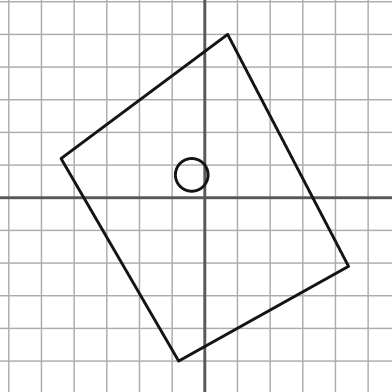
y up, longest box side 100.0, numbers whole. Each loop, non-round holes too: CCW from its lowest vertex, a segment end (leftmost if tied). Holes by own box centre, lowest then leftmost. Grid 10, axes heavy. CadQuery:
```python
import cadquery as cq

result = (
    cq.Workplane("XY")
    .moveTo(-8.0, -50.0)
    .lineTo(44.0, -21.0)
    .lineTo(7.0, 50.0)
    .lineTo(-44.0, 12.0)
    .close()
    .moveTo(-4.0, 7.0)
    .circle(5.0)
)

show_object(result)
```